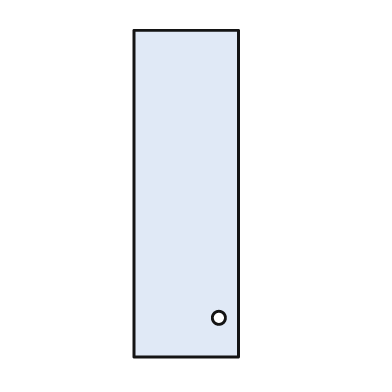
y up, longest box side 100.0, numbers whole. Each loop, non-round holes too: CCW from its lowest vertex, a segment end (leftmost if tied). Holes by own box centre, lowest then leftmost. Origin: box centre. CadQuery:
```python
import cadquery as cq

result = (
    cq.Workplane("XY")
    .moveTo(-16.0, -50.0)
    .lineTo(16.0, -50.0)
    .lineTo(16.0, 50.0)
    .lineTo(-16.0, 50.0)
    .close()
    .moveTo(10.0, -38.0)
    .circle(2.0)
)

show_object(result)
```